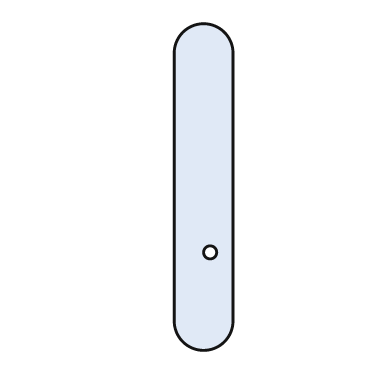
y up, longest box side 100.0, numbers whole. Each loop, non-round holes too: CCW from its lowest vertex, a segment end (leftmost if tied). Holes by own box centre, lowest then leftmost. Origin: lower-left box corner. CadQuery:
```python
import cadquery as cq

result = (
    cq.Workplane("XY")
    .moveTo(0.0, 9.0)
    .threePointArc((9.0, 0.0), (18.0, 9.0))
    .lineTo(18.0, 91.0)
    .threePointArc((9.0, 100.0), (0.0, 91.0))
    .close()
    .moveTo(11.0, 30.0)
    .circle(2.0)
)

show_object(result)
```